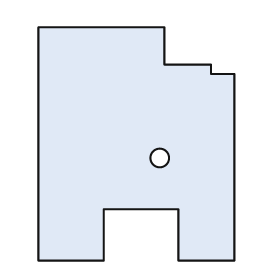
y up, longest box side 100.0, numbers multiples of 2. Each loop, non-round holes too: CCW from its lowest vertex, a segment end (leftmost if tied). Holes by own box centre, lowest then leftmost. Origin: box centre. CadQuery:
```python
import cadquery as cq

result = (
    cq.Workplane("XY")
    .moveTo(-42.0, -50.0)
    .lineTo(-14.0, -50.0)
    .lineTo(-14.0, -28.0)
    .lineTo(18.0, -28.0)
    .lineTo(18.0, -50.0)
    .lineTo(42.0, -50.0)
    .lineTo(42.0, 30.0)
    .lineTo(32.0, 30.0)
    .lineTo(32.0, 34.0)
    .lineTo(12.0, 34.0)
    .lineTo(12.0, 50.0)
    .lineTo(-42.0, 50.0)
    .close()
    .moveTo(10.0, -6.0)
    .circle(4.0)
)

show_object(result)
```